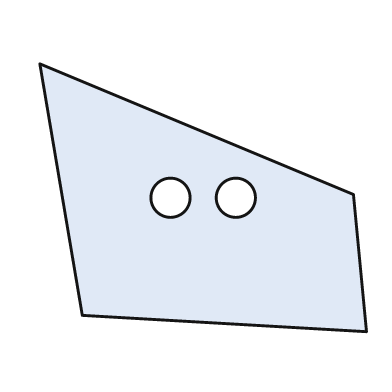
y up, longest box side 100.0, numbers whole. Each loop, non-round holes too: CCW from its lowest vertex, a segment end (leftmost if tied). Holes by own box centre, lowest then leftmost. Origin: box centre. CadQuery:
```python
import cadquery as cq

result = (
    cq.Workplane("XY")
    .moveTo(50.0, -41.0)
    .lineTo(46.0, 1.0)
    .lineTo(-50.0, 41.0)
    .lineTo(-37.0, -36.0)
    .close()
    .moveTo(-10.0, 0.0)
    .circle(6.0)
    .moveTo(10.0, 0.0)
    .circle(6.0)
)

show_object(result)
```